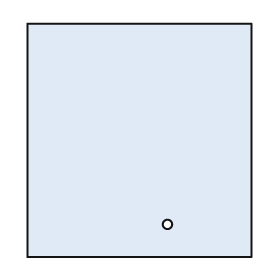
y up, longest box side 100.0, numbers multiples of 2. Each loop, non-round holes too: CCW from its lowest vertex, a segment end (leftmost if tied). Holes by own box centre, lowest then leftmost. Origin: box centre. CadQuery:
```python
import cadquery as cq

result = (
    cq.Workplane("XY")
    .moveTo(-48.0, -50.0)
    .lineTo(48.0, -50.0)
    .lineTo(48.0, 50.0)
    .lineTo(-48.0, 50.0)
    .close()
    .moveTo(12.0, -36.0)
    .circle(2.0)
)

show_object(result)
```